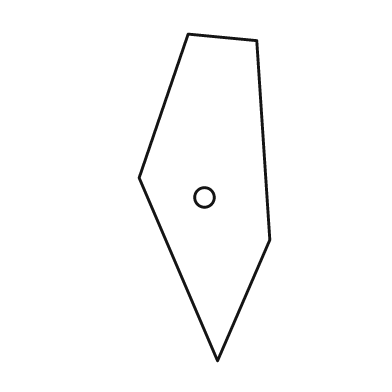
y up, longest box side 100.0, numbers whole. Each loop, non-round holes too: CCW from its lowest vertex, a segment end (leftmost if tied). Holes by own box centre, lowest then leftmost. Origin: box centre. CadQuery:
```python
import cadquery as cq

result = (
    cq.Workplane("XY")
    .moveTo(4.0, -50.0)
    .lineTo(20.0, -13.0)
    .lineTo(16.0, 48.0)
    .lineTo(-5.0, 50.0)
    .lineTo(-20.0, 6.0)
    .close()
    .moveTo(0.0, 0.0)
    .circle(3.0)
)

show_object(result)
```